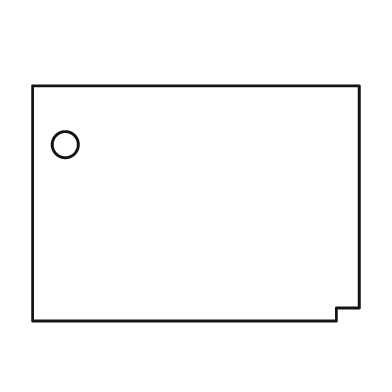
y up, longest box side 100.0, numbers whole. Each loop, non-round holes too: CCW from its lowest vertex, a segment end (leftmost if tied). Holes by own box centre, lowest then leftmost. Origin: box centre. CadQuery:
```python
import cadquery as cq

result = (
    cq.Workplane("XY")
    .moveTo(-50.0, -36.0)
    .lineTo(43.0, -36.0)
    .lineTo(43.0, -32.0)
    .lineTo(50.0, -32.0)
    .lineTo(50.0, 36.0)
    .lineTo(-50.0, 36.0)
    .close()
    .moveTo(-40.0, 18.0)
    .circle(4.0)
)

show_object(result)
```